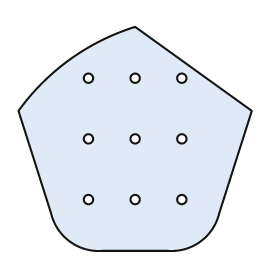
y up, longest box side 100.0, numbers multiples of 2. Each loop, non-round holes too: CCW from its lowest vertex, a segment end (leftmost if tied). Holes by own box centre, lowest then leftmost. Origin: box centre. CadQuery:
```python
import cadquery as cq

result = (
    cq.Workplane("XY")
    .moveTo(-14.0, -48.0)
    .lineTo(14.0, -48.0)
    .threePointArc((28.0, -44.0), (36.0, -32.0))
    .lineTo(50.0, 12.0)
    .lineTo(0.0, 48.0)
    .threePointArc((-28.0, 34.0), (-50.0, 12.0))
    .lineTo(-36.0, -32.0)
    .threePointArc((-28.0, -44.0), (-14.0, -48.0))
    .close()
    .moveTo(-20.0, -26.0)
    .circle(2.0)
    .moveTo(0.0, -26.0)
    .circle(2.0)
    .moveTo(20.0, -26.0)
    .circle(2.0)
    .moveTo(-20.0, 0.0)
    .circle(2.0)
    .moveTo(0.0, 0.0)
    .circle(2.0)
    .moveTo(20.0, 0.0)
    .circle(2.0)
    .moveTo(-20.0, 26.0)
    .circle(2.0)
    .moveTo(0.0, 26.0)
    .circle(2.0)
    .moveTo(20.0, 26.0)
    .circle(2.0)
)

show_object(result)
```